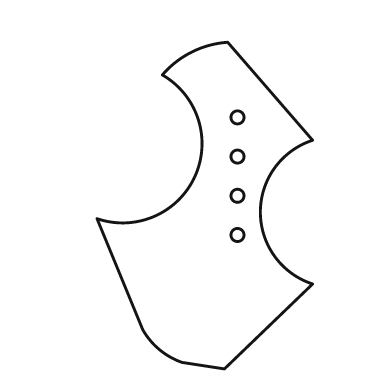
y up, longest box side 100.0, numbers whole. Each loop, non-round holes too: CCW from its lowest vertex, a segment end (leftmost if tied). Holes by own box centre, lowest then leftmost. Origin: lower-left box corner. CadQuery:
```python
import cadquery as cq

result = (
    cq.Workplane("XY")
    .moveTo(39.0, 0.0)
    .lineTo(66.0, 26.0)
    .threePointArc((50.0, 48.0), (66.0, 70.0))
    .lineTo(40.0, 100.0)
    .threePointArc((29.0, 97.0), (20.0, 90.0))
    .threePointArc((30.0, 59.0), (0.0, 46.0))
    .lineTo(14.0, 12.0)
    .threePointArc((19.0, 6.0), (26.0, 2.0))
    .close()
    .moveTo(43.0, 41.0)
    .circle(2.0)
    .moveTo(43.0, 53.0)
    .circle(2.0)
    .moveTo(43.0, 65.0)
    .circle(2.0)
    .moveTo(43.0, 77.0)
    .circle(2.0)
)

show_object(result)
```